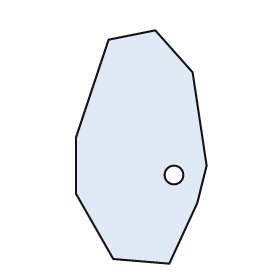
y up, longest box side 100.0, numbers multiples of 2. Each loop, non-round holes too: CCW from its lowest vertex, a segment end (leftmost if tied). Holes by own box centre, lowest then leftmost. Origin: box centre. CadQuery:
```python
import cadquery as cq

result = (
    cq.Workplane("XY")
    .moveTo(12.0, -50.0)
    .lineTo(24.0, -24.0)
    .lineTo(28.0, -8.0)
    .lineTo(22.0, 32.0)
    .lineTo(6.0, 50.0)
    .lineTo(-14.0, 46.0)
    .lineTo(-28.0, 4.0)
    .lineTo(-28.0, -20.0)
    .lineTo(-12.0, -48.0)
    .close()
    .moveTo(14.0, -12.0)
    .circle(4.0)
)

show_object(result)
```